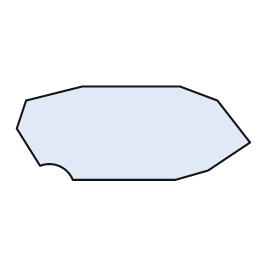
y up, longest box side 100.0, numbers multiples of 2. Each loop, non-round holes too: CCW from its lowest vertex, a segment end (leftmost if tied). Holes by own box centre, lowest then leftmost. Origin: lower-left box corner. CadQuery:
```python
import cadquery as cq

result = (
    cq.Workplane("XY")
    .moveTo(24.0, 0.0)
    .lineTo(68.0, 0.0)
    .lineTo(82.0, 4.0)
    .lineTo(100.0, 16.0)
    .lineTo(86.0, 34.0)
    .lineTo(70.0, 40.0)
    .lineTo(28.0, 40.0)
    .lineTo(4.0, 34.0)
    .lineTo(0.0, 22.0)
    .lineTo(10.0, 6.0)
    .threePointArc((18.0, 6.0), (24.0, 0.0))
    .close()
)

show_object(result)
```